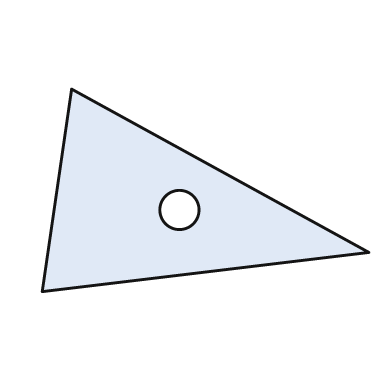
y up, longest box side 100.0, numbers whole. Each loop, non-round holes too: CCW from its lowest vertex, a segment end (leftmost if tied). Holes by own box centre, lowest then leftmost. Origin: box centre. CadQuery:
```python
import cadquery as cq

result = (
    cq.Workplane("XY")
    .moveTo(-50.0, -31.0)
    .lineTo(50.0, -19.0)
    .lineTo(-41.0, 31.0)
    .close()
    .moveTo(-8.0, -6.0)
    .circle(6.0)
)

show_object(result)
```